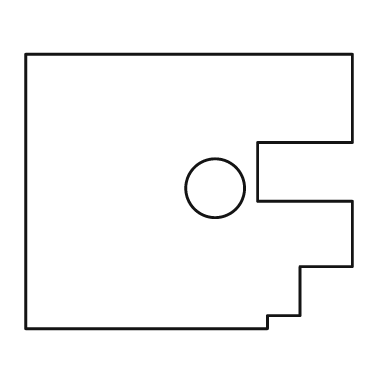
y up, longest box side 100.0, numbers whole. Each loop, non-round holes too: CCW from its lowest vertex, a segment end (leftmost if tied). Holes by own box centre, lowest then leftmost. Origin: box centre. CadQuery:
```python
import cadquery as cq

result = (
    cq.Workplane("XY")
    .moveTo(-50.0, -42.0)
    .lineTo(24.0, -42.0)
    .lineTo(24.0, -38.0)
    .lineTo(34.0, -38.0)
    .lineTo(34.0, -23.0)
    .lineTo(50.0, -23.0)
    .lineTo(50.0, -3.0)
    .lineTo(21.0, -3.0)
    .lineTo(21.0, 15.0)
    .lineTo(50.0, 15.0)
    .lineTo(50.0, 42.0)
    .lineTo(-50.0, 42.0)
    .close()
    .moveTo(8.0, 1.0)
    .circle(9.0)
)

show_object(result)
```